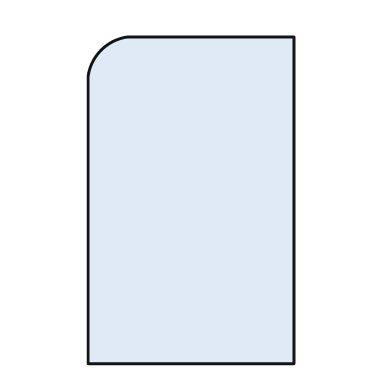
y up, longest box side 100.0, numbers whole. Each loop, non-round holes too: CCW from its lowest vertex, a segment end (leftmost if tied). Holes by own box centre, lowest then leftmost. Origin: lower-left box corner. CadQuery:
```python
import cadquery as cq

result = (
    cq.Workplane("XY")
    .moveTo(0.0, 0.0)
    .lineTo(63.0, 0.0)
    .lineTo(63.0, 100.0)
    .lineTo(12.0, 100.0)
    .threePointArc((4.0, 96.0), (0.0, 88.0))
    .close()
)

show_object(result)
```